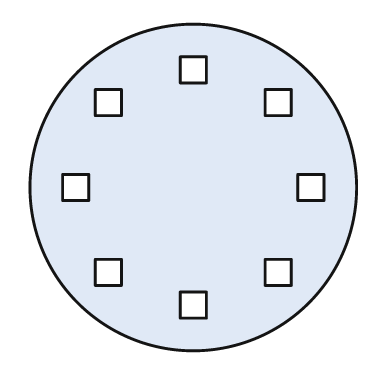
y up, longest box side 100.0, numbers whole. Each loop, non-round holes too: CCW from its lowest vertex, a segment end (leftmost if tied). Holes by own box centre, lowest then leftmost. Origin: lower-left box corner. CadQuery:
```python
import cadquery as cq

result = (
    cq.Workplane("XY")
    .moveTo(50.0, 50.0)
    .circle(50.0)
    .moveTo(46.0, 10.0)
    .lineTo(54.0, 10.0)
    .lineTo(54.0, 18.0)
    .lineTo(46.0, 18.0)
    .close()
    .moveTo(20.0, 20.0)
    .lineTo(28.0, 20.0)
    .lineTo(28.0, 28.0)
    .lineTo(20.0, 28.0)
    .close()
    .moveTo(72.0, 20.0)
    .lineTo(80.0, 20.0)
    .lineTo(80.0, 28.0)
    .lineTo(72.0, 28.0)
    .close()
    .moveTo(10.0, 46.0)
    .lineTo(18.0, 46.0)
    .lineTo(18.0, 54.0)
    .lineTo(10.0, 54.0)
    .close()
    .moveTo(82.0, 46.0)
    .lineTo(90.0, 46.0)
    .lineTo(90.0, 54.0)
    .lineTo(82.0, 54.0)
    .close()
    .moveTo(20.0, 72.0)
    .lineTo(28.0, 72.0)
    .lineTo(28.0, 80.0)
    .lineTo(20.0, 80.0)
    .close()
    .moveTo(72.0, 72.0)
    .lineTo(80.0, 72.0)
    .lineTo(80.0, 80.0)
    .lineTo(72.0, 80.0)
    .close()
    .moveTo(46.0, 82.0)
    .lineTo(54.0, 82.0)
    .lineTo(54.0, 90.0)
    .lineTo(46.0, 90.0)
    .close()
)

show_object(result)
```